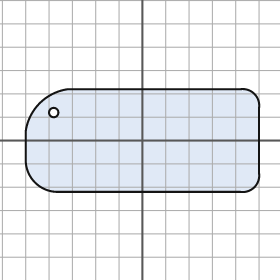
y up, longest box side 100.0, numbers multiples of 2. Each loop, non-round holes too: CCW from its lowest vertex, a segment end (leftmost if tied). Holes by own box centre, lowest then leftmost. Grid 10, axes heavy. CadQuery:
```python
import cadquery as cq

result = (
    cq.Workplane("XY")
    .moveTo(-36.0, -22.0)
    .lineTo(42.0, -22.0)
    .threePointArc((48.0, -20.0), (50.0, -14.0))
    .lineTo(50.0, 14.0)
    .threePointArc((48.0, 20.0), (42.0, 22.0))
    .lineTo(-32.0, 22.0)
    .threePointArc((-44.0, 16.0), (-50.0, 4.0))
    .lineTo(-50.0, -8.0)
    .threePointArc((-46.0, -18.0), (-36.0, -22.0))
    .close()
    .moveTo(-38.0, 12.0)
    .circle(2.0)
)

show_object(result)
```